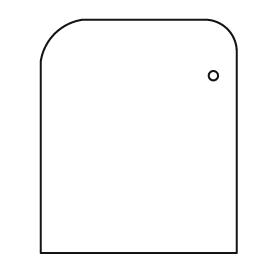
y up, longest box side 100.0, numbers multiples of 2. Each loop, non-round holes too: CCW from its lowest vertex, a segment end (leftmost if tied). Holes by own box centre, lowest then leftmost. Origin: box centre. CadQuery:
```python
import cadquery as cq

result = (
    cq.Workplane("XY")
    .moveTo(-42.0, -50.0)
    .lineTo(42.0, -50.0)
    .lineTo(42.0, 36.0)
    .threePointArc((38.0, 46.0), (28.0, 50.0))
    .lineTo(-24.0, 50.0)
    .threePointArc((-36.0, 44.0), (-42.0, 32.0))
    .close()
    .moveTo(32.0, 26.0)
    .circle(2.0)
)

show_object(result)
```